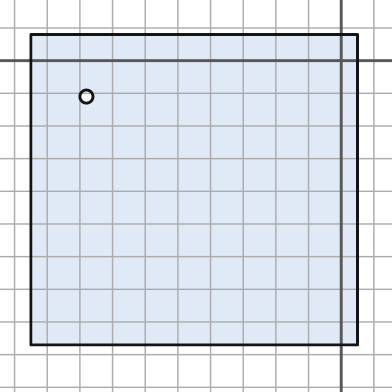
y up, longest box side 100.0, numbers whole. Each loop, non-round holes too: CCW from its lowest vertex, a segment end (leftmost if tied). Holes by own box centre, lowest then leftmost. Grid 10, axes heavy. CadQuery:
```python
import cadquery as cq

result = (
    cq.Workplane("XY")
    .moveTo(-95.0, -87.0)
    .lineTo(5.0, -87.0)
    .lineTo(5.0, 8.0)
    .lineTo(-95.0, 8.0)
    .close()
    .moveTo(-78.0, -11.0)
    .circle(2.0)
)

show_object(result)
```